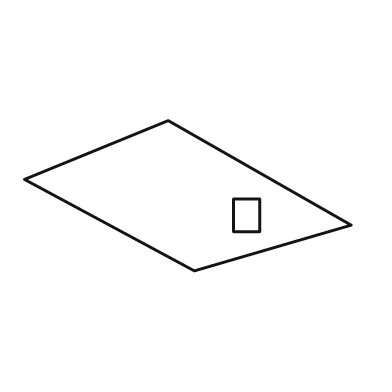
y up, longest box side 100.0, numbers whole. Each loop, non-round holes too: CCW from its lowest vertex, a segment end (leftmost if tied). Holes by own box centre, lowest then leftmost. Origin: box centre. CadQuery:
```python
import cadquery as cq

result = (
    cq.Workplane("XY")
    .moveTo(2.0, -23.0)
    .lineTo(50.0, -9.0)
    .lineTo(-6.0, 23.0)
    .lineTo(-50.0, 5.0)
    .close()
    .moveTo(14.0, -11.0)
    .lineTo(22.0, -11.0)
    .lineTo(22.0, -1.0)
    .lineTo(14.0, -1.0)
    .close()
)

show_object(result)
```